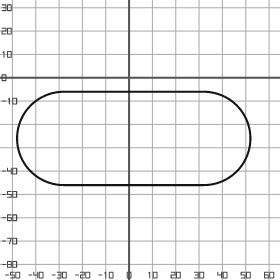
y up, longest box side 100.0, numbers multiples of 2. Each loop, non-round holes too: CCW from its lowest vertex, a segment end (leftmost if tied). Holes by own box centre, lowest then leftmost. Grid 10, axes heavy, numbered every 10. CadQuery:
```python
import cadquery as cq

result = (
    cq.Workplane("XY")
    .moveTo(-28.0, -46.0)
    .lineTo(32.0, -46.0)
    .threePointArc((52.0, -26.0), (32.0, -6.0))
    .lineTo(-28.0, -6.0)
    .threePointArc((-48.0, -26.0), (-28.0, -46.0))
    .close()
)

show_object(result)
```